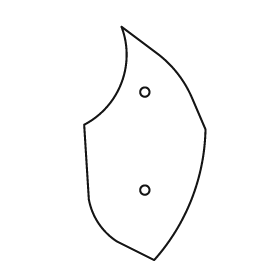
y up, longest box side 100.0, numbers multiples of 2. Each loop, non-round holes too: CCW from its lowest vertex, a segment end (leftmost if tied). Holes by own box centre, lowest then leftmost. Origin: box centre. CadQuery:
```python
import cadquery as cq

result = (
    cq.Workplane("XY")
    .moveTo(4.0, -50.0)
    .threePointArc((20.0, -24.0), (26.0, 6.0))
    .lineTo(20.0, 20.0)
    .threePointArc((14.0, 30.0), (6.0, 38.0))
    .lineTo(-10.0, 50.0)
    .threePointArc((-10.0, 26.0), (-26.0, 8.0))
    .lineTo(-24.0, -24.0)
    .threePointArc((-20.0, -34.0), (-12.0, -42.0))
    .close()
    .moveTo(0.0, -20.0)
    .circle(2.0)
    .moveTo(0.0, 22.0)
    .circle(2.0)
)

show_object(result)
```